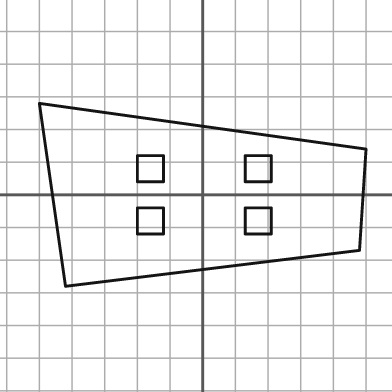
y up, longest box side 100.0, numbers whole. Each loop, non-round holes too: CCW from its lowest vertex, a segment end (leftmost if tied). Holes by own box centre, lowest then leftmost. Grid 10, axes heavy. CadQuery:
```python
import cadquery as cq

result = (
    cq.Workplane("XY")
    .moveTo(-42.0, -28.0)
    .lineTo(48.0, -17.0)
    .lineTo(50.0, 14.0)
    .lineTo(-50.0, 28.0)
    .close()
    .moveTo(-20.0, -12.0)
    .lineTo(-12.0, -12.0)
    .lineTo(-12.0, -4.0)
    .lineTo(-20.0, -4.0)
    .close()
    .moveTo(13.0, -12.0)
    .lineTo(21.0, -12.0)
    .lineTo(21.0, -4.0)
    .lineTo(13.0, -4.0)
    .close()
    .moveTo(-20.0, 4.0)
    .lineTo(-12.0, 4.0)
    .lineTo(-12.0, 12.0)
    .lineTo(-20.0, 12.0)
    .close()
    .moveTo(13.0, 4.0)
    .lineTo(21.0, 4.0)
    .lineTo(21.0, 12.0)
    .lineTo(13.0, 12.0)
    .close()
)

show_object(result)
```